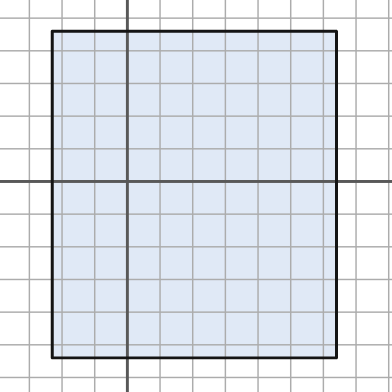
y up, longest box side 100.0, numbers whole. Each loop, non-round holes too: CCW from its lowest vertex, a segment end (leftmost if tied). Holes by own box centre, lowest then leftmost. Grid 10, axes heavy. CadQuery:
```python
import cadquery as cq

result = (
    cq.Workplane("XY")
    .moveTo(-23.0, -54.0)
    .lineTo(64.0, -54.0)
    .lineTo(64.0, 46.0)
    .lineTo(-23.0, 46.0)
    .close()
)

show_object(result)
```